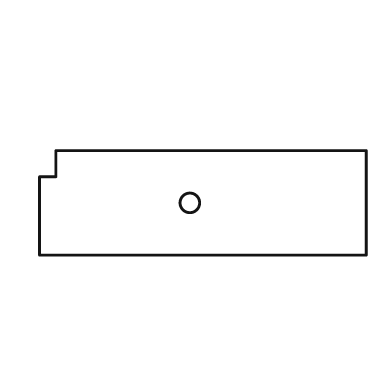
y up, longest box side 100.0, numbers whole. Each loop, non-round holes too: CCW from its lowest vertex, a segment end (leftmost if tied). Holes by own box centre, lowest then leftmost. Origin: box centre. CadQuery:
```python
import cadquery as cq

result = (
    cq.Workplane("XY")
    .moveTo(-50.0, -16.0)
    .lineTo(50.0, -16.0)
    .lineTo(50.0, 16.0)
    .lineTo(-45.0, 16.0)
    .lineTo(-45.0, 8.0)
    .lineTo(-50.0, 8.0)
    .close()
    .moveTo(-4.0, 0.0)
    .circle(3.0)
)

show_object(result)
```